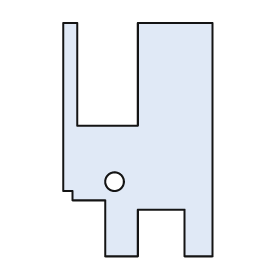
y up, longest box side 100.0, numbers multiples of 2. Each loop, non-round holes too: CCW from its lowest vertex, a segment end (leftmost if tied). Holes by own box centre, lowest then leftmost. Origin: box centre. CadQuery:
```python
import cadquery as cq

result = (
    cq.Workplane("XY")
    .moveTo(-14.0, -50.0)
    .lineTo(0.0, -50.0)
    .lineTo(0.0, -30.0)
    .lineTo(20.0, -30.0)
    .lineTo(20.0, -50.0)
    .lineTo(32.0, -50.0)
    .lineTo(32.0, 50.0)
    .lineTo(0.0, 50.0)
    .lineTo(0.0, 6.0)
    .lineTo(-26.0, 6.0)
    .lineTo(-26.0, 50.0)
    .lineTo(-32.0, 50.0)
    .lineTo(-32.0, -22.0)
    .lineTo(-28.0, -22.0)
    .lineTo(-28.0, -26.0)
    .lineTo(-14.0, -26.0)
    .close()
    .moveTo(-10.0, -18.0)
    .circle(4.0)
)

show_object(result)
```